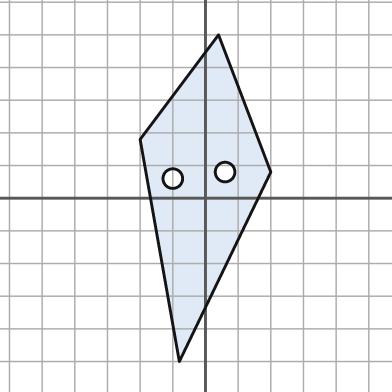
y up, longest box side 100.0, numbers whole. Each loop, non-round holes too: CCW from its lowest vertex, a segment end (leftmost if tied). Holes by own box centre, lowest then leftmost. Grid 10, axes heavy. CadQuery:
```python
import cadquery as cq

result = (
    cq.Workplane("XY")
    .moveTo(-8.0, -50.0)
    .lineTo(20.0, 8.0)
    .lineTo(4.0, 50.0)
    .lineTo(-20.0, 18.0)
    .close()
    .moveTo(-10.0, 6.0)
    .circle(3.0)
    .moveTo(6.0, 8.0)
    .circle(3.0)
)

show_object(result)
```